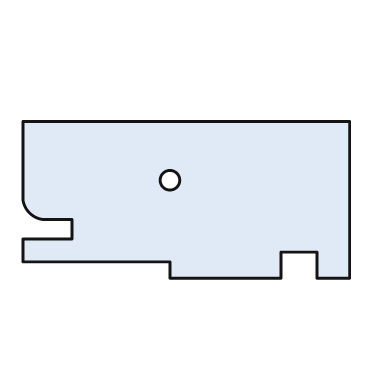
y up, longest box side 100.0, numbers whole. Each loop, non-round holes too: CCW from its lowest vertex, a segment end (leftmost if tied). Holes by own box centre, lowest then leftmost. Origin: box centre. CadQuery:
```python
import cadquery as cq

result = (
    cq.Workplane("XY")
    .moveTo(-5.0, -24.0)
    .lineTo(29.0, -24.0)
    .lineTo(29.0, -16.0)
    .lineTo(40.0, -16.0)
    .lineTo(40.0, -24.0)
    .lineTo(50.0, -24.0)
    .lineTo(50.0, 24.0)
    .lineTo(-50.0, 24.0)
    .lineTo(-50.0, 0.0)
    .threePointArc((-48.0, -4.0), (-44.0, -6.0))
    .lineTo(-35.0, -6.0)
    .lineTo(-35.0, -12.0)
    .lineTo(-50.0, -12.0)
    .lineTo(-50.0, -19.0)
    .lineTo(-5.0, -19.0)
    .close()
    .moveTo(-5.0, 6.0)
    .circle(3.0)
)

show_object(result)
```